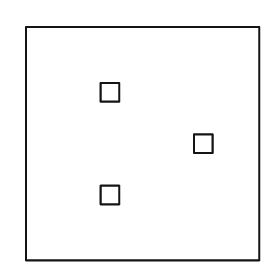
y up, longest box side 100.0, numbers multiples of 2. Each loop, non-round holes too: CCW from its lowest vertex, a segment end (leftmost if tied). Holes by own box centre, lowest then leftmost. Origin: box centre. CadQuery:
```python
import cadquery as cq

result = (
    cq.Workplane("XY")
    .moveTo(-50.0, -50.0)
    .lineTo(50.0, -50.0)
    .lineTo(50.0, 50.0)
    .lineTo(-50.0, 50.0)
    .close()
    .moveTo(-18.0, -26.0)
    .lineTo(-10.0, -26.0)
    .lineTo(-10.0, -18.0)
    .lineTo(-18.0, -18.0)
    .close()
    .moveTo(22.0, -4.0)
    .lineTo(30.0, -4.0)
    .lineTo(30.0, 4.0)
    .lineTo(22.0, 4.0)
    .close()
    .moveTo(-18.0, 18.0)
    .lineTo(-10.0, 18.0)
    .lineTo(-10.0, 26.0)
    .lineTo(-18.0, 26.0)
    .close()
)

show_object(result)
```